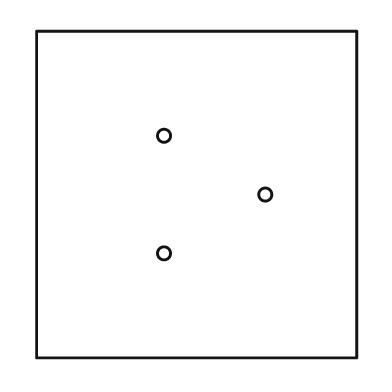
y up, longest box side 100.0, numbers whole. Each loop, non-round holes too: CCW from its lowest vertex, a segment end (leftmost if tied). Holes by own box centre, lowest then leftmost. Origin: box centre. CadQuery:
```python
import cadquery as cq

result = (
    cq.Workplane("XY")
    .moveTo(-49.0, -50.0)
    .lineTo(49.0, -50.0)
    .lineTo(49.0, 50.0)
    .lineTo(-49.0, 50.0)
    .close()
    .moveTo(-10.0, -18.0)
    .circle(2.0)
    .moveTo(21.0, 0.0)
    .circle(2.0)
    .moveTo(-10.0, 18.0)
    .circle(2.0)
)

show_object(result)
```